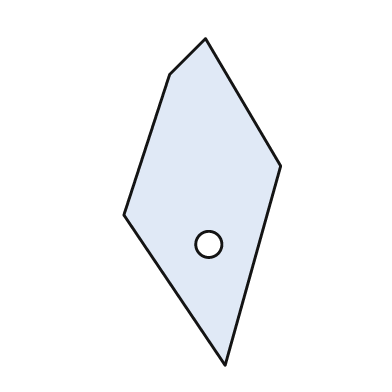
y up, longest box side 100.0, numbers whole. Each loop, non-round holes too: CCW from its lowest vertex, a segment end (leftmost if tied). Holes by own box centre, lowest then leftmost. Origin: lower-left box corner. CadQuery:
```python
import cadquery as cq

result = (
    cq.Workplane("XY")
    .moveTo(31.0, 0.0)
    .lineTo(48.0, 61.0)
    .lineTo(25.0, 100.0)
    .lineTo(14.0, 89.0)
    .lineTo(0.0, 46.0)
    .close()
    .moveTo(26.0, 37.0)
    .circle(4.0)
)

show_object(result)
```